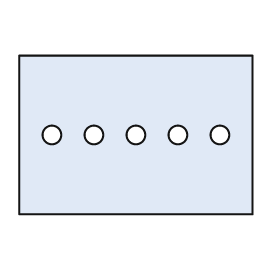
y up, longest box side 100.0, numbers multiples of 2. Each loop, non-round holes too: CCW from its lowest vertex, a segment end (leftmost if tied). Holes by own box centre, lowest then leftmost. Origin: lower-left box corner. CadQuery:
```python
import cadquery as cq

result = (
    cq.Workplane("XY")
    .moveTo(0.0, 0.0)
    .lineTo(100.0, 0.0)
    .lineTo(100.0, 68.0)
    .lineTo(0.0, 68.0)
    .close()
    .moveTo(14.0, 34.0)
    .circle(4.0)
    .moveTo(32.0, 34.0)
    .circle(4.0)
    .moveTo(50.0, 34.0)
    .circle(4.0)
    .moveTo(68.0, 34.0)
    .circle(4.0)
    .moveTo(86.0, 34.0)
    .circle(4.0)
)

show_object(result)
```